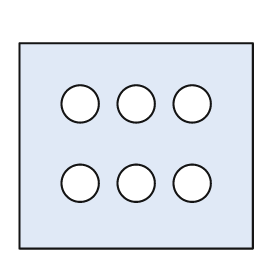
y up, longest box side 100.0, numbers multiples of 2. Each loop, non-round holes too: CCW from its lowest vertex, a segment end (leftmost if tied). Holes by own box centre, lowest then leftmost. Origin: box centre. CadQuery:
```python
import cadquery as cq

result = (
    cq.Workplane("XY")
    .moveTo(-50.0, -44.0)
    .lineTo(50.0, -44.0)
    .lineTo(50.0, 44.0)
    .lineTo(-50.0, 44.0)
    .close()
    .moveTo(-24.0, -16.0)
    .circle(8.0)
    .moveTo(0.0, -16.0)
    .circle(8.0)
    .moveTo(24.0, -16.0)
    .circle(8.0)
    .moveTo(-24.0, 18.0)
    .circle(8.0)
    .moveTo(0.0, 18.0)
    .circle(8.0)
    .moveTo(24.0, 18.0)
    .circle(8.0)
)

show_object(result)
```